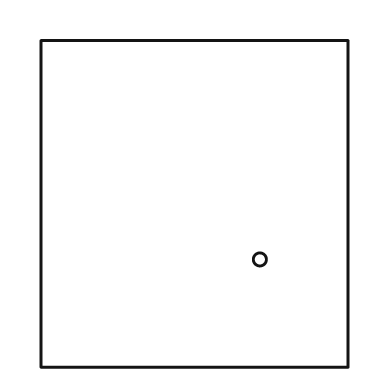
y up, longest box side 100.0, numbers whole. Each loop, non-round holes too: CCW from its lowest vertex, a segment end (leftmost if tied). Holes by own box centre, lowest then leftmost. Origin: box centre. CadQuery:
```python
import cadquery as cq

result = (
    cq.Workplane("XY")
    .moveTo(-47.0, -50.0)
    .lineTo(47.0, -50.0)
    .lineTo(47.0, 50.0)
    .lineTo(-47.0, 50.0)
    .close()
    .moveTo(20.0, -17.0)
    .circle(2.0)
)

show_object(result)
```